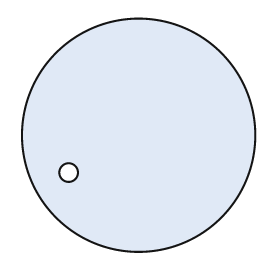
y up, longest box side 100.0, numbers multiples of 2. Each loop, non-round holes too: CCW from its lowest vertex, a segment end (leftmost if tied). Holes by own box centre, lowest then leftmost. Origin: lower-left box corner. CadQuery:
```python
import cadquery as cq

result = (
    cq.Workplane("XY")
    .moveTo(50.0, 50.0)
    .circle(50.0)
    .moveTo(20.0, 34.0)
    .circle(4.0)
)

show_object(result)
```